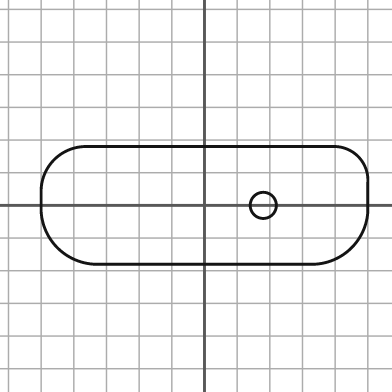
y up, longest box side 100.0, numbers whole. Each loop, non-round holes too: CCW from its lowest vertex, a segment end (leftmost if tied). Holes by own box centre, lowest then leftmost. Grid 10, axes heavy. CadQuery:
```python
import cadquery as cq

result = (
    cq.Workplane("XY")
    .moveTo(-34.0, -18.0)
    .lineTo(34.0, -18.0)
    .threePointArc((45.0, -13.0), (50.0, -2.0))
    .lineTo(50.0, 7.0)
    .threePointArc((47.0, 15.0), (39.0, 18.0))
    .lineTo(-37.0, 18.0)
    .threePointArc((-46.0, 14.0), (-50.0, 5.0))
    .lineTo(-50.0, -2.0)
    .threePointArc((-45.0, -13.0), (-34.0, -18.0))
    .close()
    .moveTo(18.0, 0.0)
    .circle(4.0)
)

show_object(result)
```